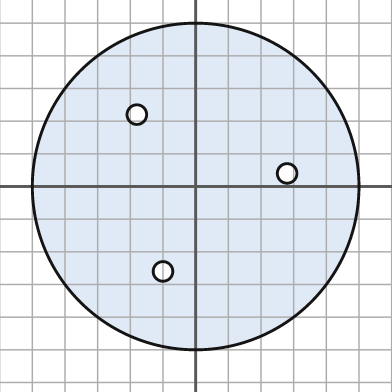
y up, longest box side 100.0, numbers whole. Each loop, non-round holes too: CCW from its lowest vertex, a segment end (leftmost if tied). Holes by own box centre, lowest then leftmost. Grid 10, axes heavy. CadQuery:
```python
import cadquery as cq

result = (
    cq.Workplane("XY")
    .moveTo(0.0, 0.0)
    .circle(50.0)
    .moveTo(-10.0, -26.0)
    .circle(3.0)
    .moveTo(28.0, 4.0)
    .circle(3.0)
    .moveTo(-18.0, 22.0)
    .circle(3.0)
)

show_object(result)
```